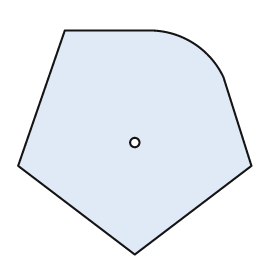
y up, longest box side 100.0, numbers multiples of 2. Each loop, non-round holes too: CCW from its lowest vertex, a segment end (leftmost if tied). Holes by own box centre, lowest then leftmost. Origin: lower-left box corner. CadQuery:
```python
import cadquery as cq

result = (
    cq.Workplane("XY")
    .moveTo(50.0, 0.0)
    .lineTo(100.0, 38.0)
    .lineTo(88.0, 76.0)
    .threePointArc((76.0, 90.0), (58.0, 96.0))
    .lineTo(20.0, 96.0)
    .lineTo(0.0, 38.0)
    .close()
    .moveTo(50.0, 48.0)
    .circle(2.0)
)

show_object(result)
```